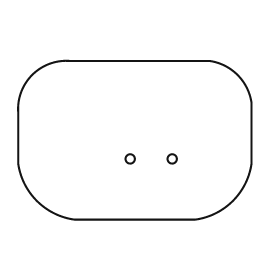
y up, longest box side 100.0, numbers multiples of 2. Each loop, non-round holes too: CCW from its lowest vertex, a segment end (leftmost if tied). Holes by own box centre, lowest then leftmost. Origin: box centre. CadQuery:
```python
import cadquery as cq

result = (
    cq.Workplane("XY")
    .moveTo(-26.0, -34.0)
    .lineTo(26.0, -34.0)
    .threePointArc((42.0, -26.0), (50.0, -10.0))
    .lineTo(50.0, 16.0)
    .threePointArc((44.0, 28.0), (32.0, 34.0))
    .lineTo(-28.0, 34.0)
    .threePointArc((-44.0, 28.0), (-50.0, 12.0))
    .lineTo(-50.0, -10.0)
    .threePointArc((-42.0, -26.0), (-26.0, -34.0))
    .close()
    .moveTo(-2.0, -8.0)
    .circle(2.0)
    .moveTo(16.0, -8.0)
    .circle(2.0)
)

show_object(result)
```